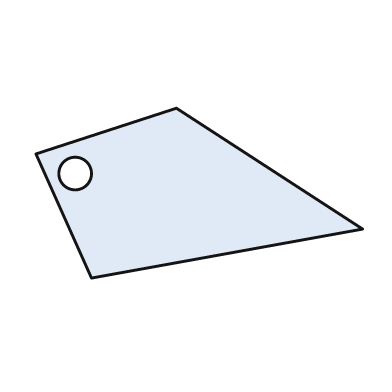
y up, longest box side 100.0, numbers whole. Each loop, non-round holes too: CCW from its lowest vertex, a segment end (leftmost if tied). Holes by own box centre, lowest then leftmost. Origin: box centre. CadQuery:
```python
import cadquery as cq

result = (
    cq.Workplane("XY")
    .moveTo(-33.0, -26.0)
    .lineTo(50.0, -11.0)
    .lineTo(-7.0, 26.0)
    .lineTo(-50.0, 12.0)
    .close()
    .moveTo(-38.0, 6.0)
    .circle(5.0)
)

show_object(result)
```